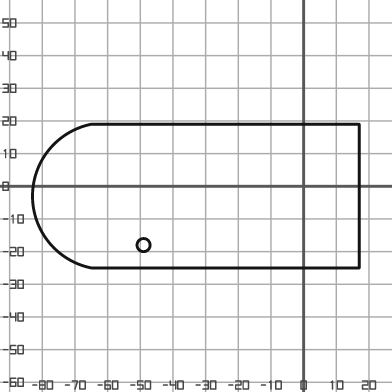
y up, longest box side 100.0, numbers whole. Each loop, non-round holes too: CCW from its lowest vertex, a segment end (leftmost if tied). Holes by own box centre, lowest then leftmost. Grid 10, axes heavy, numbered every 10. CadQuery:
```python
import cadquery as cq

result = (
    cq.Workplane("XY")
    .moveTo(-65.0, -25.0)
    .lineTo(17.0, -25.0)
    .lineTo(17.0, 19.0)
    .lineTo(-65.0, 19.0)
    .threePointArc((-83.0, -3.0), (-65.0, -25.0))
    .close()
    .moveTo(-49.0, -18.0)
    .circle(2.0)
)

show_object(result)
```